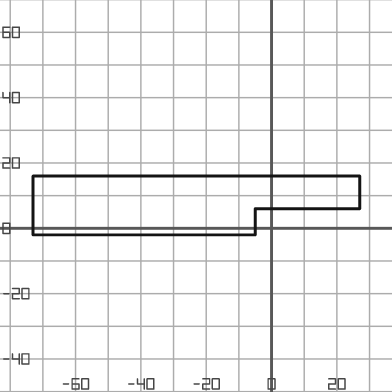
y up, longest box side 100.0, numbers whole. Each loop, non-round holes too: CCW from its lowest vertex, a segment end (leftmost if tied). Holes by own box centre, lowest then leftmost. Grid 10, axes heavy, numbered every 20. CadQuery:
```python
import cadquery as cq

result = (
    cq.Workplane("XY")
    .moveTo(-73.0, -2.0)
    .lineTo(-5.0, -2.0)
    .lineTo(-5.0, 6.0)
    .lineTo(27.0, 6.0)
    .lineTo(27.0, 16.0)
    .lineTo(-73.0, 16.0)
    .close()
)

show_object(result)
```